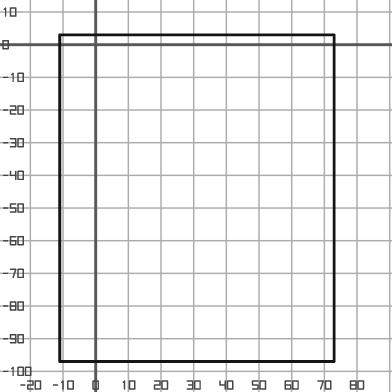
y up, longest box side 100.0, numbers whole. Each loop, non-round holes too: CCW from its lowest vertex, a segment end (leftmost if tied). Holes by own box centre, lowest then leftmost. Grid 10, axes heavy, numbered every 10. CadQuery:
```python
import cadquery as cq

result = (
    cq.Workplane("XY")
    .moveTo(-11.0, -97.0)
    .lineTo(73.0, -97.0)
    .lineTo(73.0, 3.0)
    .lineTo(-11.0, 3.0)
    .close()
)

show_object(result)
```